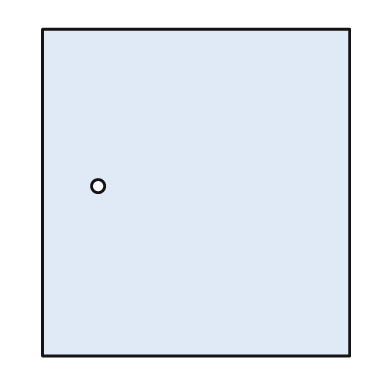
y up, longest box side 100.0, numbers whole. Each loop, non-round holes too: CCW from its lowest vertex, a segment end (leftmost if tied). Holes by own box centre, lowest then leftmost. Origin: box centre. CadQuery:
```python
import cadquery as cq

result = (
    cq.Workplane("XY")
    .moveTo(-47.0, -50.0)
    .lineTo(47.0, -50.0)
    .lineTo(47.0, 50.0)
    .lineTo(-47.0, 50.0)
    .close()
    .moveTo(-30.0, 2.0)
    .circle(2.0)
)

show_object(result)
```